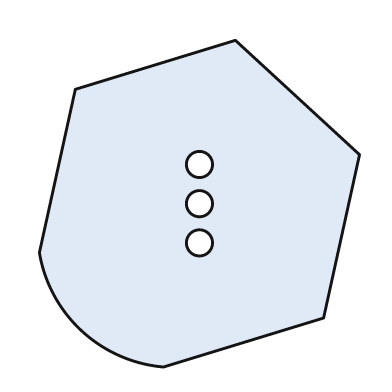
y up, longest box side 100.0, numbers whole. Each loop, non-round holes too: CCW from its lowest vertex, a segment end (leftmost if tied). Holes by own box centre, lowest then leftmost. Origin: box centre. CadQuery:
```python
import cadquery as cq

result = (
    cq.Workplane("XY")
    .moveTo(-11.0, -50.0)
    .lineTo(38.0, -35.0)
    .lineTo(49.0, 15.0)
    .lineTo(11.0, 50.0)
    .lineTo(-38.0, 35.0)
    .lineTo(-49.0, -15.0)
    .threePointArc((-36.0, -39.0), (-11.0, -50.0))
    .close()
    .moveTo(0.0, -12.0)
    .circle(4.0)
    .moveTo(0.0, 0.0)
    .circle(4.0)
    .moveTo(0.0, 12.0)
    .circle(4.0)
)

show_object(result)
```